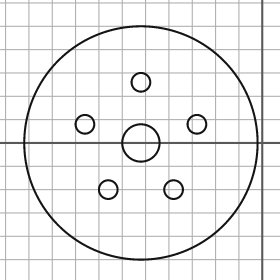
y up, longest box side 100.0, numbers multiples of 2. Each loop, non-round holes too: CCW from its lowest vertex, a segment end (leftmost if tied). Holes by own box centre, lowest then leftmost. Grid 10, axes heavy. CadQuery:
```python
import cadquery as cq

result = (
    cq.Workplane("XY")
    .moveTo(-52.0, 0.0)
    .circle(50.0)
    .moveTo(-66.0, -20.0)
    .circle(4.0)
    .moveTo(-38.0, -20.0)
    .circle(4.0)
    .moveTo(-52.0, 0.0)
    .circle(8.0)
    .moveTo(-76.0, 8.0)
    .circle(4.0)
    .moveTo(-28.0, 8.0)
    .circle(4.0)
    .moveTo(-52.0, 26.0)
    .circle(4.0)
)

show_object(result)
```